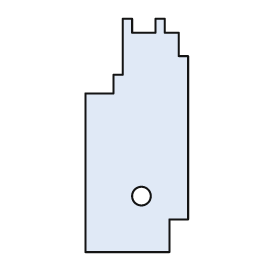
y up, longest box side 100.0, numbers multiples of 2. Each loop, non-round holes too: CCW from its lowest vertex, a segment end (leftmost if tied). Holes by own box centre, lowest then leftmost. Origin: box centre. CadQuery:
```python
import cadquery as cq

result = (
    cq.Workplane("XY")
    .moveTo(-22.0, -50.0)
    .lineTo(14.0, -50.0)
    .lineTo(14.0, -36.0)
    .lineTo(22.0, -36.0)
    .lineTo(22.0, 34.0)
    .lineTo(18.0, 34.0)
    .lineTo(18.0, 44.0)
    .lineTo(12.0, 44.0)
    .lineTo(12.0, 50.0)
    .lineTo(8.0, 50.0)
    .lineTo(8.0, 44.0)
    .lineTo(-2.0, 44.0)
    .lineTo(-2.0, 50.0)
    .lineTo(-6.0, 50.0)
    .lineTo(-6.0, 26.0)
    .lineTo(-10.0, 26.0)
    .lineTo(-10.0, 18.0)
    .lineTo(-22.0, 18.0)
    .close()
    .moveTo(2.0, -26.0)
    .circle(4.0)
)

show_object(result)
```